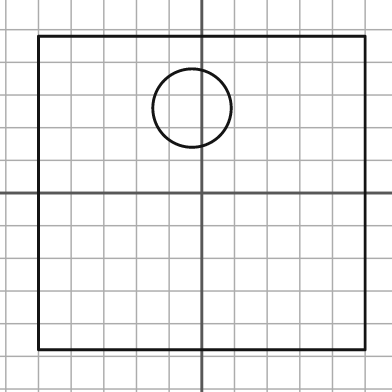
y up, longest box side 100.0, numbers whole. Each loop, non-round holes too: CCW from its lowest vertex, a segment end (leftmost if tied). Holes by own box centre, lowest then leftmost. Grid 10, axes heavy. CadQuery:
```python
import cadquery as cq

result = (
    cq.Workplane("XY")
    .moveTo(-50.0, -48.0)
    .lineTo(50.0, -48.0)
    .lineTo(50.0, 48.0)
    .lineTo(-50.0, 48.0)
    .close()
    .moveTo(-3.0, 26.0)
    .circle(12.0)
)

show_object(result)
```